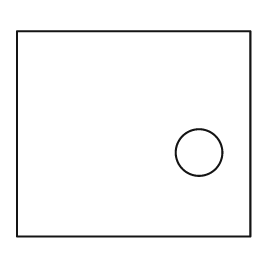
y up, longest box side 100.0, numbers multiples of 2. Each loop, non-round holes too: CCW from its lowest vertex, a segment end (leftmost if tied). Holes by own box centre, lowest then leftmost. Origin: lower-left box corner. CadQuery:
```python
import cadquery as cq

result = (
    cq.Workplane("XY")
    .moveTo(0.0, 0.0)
    .lineTo(100.0, 0.0)
    .lineTo(100.0, 88.0)
    .lineTo(0.0, 88.0)
    .close()
    .moveTo(78.0, 36.0)
    .circle(10.0)
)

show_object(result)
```